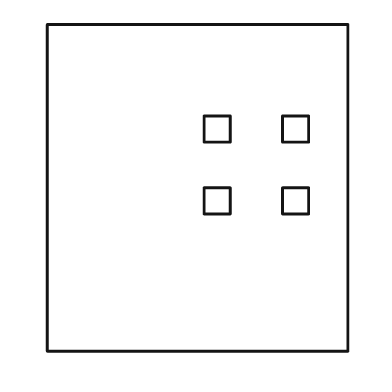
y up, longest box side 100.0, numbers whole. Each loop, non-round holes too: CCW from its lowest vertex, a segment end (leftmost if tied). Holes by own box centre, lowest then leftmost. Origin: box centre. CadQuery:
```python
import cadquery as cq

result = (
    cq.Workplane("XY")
    .moveTo(-46.0, -50.0)
    .lineTo(46.0, -50.0)
    .lineTo(46.0, 50.0)
    .lineTo(-46.0, 50.0)
    .close()
    .moveTo(2.0, -8.0)
    .lineTo(10.0, -8.0)
    .lineTo(10.0, 0.0)
    .lineTo(2.0, 0.0)
    .close()
    .moveTo(26.0, -8.0)
    .lineTo(34.0, -8.0)
    .lineTo(34.0, 0.0)
    .lineTo(26.0, 0.0)
    .close()
    .moveTo(2.0, 14.0)
    .lineTo(10.0, 14.0)
    .lineTo(10.0, 22.0)
    .lineTo(2.0, 22.0)
    .close()
    .moveTo(26.0, 14.0)
    .lineTo(34.0, 14.0)
    .lineTo(34.0, 22.0)
    .lineTo(26.0, 22.0)
    .close()
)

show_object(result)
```